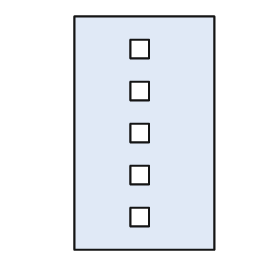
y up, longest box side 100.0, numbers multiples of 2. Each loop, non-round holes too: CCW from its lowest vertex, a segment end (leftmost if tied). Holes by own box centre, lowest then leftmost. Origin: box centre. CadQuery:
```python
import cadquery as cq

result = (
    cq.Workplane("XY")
    .moveTo(-30.0, -50.0)
    .lineTo(30.0, -50.0)
    .lineTo(30.0, 50.0)
    .lineTo(-30.0, 50.0)
    .close()
    .moveTo(-6.0, -40.0)
    .lineTo(2.0, -40.0)
    .lineTo(2.0, -32.0)
    .lineTo(-6.0, -32.0)
    .close()
    .moveTo(-6.0, -22.0)
    .lineTo(2.0, -22.0)
    .lineTo(2.0, -14.0)
    .lineTo(-6.0, -14.0)
    .close()
    .moveTo(-6.0, -4.0)
    .lineTo(2.0, -4.0)
    .lineTo(2.0, 4.0)
    .lineTo(-6.0, 4.0)
    .close()
    .moveTo(-6.0, 14.0)
    .lineTo(2.0, 14.0)
    .lineTo(2.0, 22.0)
    .lineTo(-6.0, 22.0)
    .close()
    .moveTo(-6.0, 32.0)
    .lineTo(2.0, 32.0)
    .lineTo(2.0, 40.0)
    .lineTo(-6.0, 40.0)
    .close()
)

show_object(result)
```